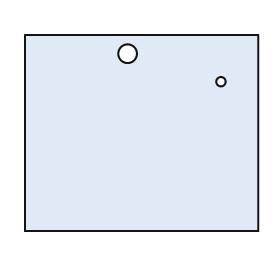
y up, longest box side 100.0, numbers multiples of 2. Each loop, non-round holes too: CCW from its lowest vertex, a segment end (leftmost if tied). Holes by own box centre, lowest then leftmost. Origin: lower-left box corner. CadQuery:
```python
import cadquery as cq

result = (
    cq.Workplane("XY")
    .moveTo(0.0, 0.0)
    .lineTo(100.0, 0.0)
    .lineTo(100.0, 84.0)
    .lineTo(0.0, 84.0)
    .close()
    .moveTo(84.0, 64.0)
    .circle(2.0)
    .moveTo(44.0, 76.0)
    .circle(4.0)
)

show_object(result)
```